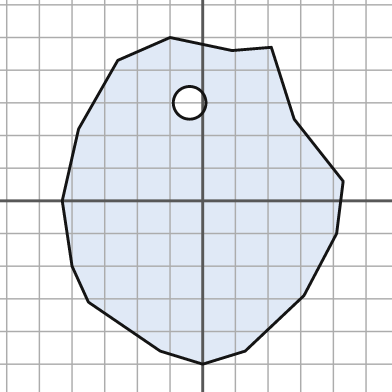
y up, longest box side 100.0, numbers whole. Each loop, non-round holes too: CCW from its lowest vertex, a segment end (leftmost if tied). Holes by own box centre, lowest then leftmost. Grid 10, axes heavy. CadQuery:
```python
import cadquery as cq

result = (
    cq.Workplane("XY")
    .moveTo(0.0, -50.0)
    .lineTo(13.0, -46.0)
    .lineTo(31.0, -29.0)
    .lineTo(41.0, -10.0)
    .lineTo(43.0, 6.0)
    .lineTo(28.0, 25.0)
    .lineTo(21.0, 47.0)
    .lineTo(9.0, 46.0)
    .lineTo(-10.0, 50.0)
    .lineTo(-26.0, 43.0)
    .lineTo(-38.0, 22.0)
    .lineTo(-43.0, 0.0)
    .lineTo(-40.0, -20.0)
    .lineTo(-35.0, -31.0)
    .lineTo(-13.0, -46.0)
    .close()
    .moveTo(-4.0, 30.0)
    .circle(5.0)
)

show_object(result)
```